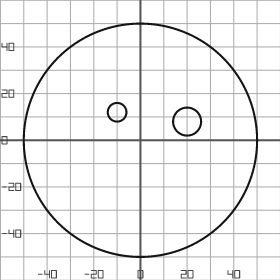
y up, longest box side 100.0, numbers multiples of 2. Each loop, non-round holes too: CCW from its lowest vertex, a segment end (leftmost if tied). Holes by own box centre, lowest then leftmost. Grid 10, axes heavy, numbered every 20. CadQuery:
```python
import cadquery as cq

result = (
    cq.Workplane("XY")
    .moveTo(0.0, 0.0)
    .circle(50.0)
    .moveTo(20.0, 8.0)
    .circle(6.0)
    .moveTo(-10.0, 12.0)
    .circle(4.0)
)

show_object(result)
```